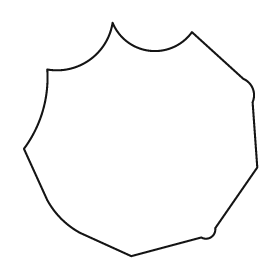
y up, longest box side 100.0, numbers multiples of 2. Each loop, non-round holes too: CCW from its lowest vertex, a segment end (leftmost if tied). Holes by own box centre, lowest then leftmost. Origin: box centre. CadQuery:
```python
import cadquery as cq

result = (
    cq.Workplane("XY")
    .moveTo(-4.0, -50.0)
    .lineTo(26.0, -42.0)
    .threePointArc((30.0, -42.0), (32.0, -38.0))
    .lineTo(50.0, -12.0)
    .lineTo(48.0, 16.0)
    .threePointArc((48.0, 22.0), (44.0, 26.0))
    .lineTo(22.0, 46.0)
    .threePointArc((4.0, 38.0), (-12.0, 50.0))
    .threePointArc((-22.0, 34.0), (-40.0, 30.0))
    .threePointArc((-42.0, 12.0), (-50.0, -4.0))
    .lineTo(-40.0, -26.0)
    .threePointArc((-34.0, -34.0), (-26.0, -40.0))
    .close()
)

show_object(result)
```